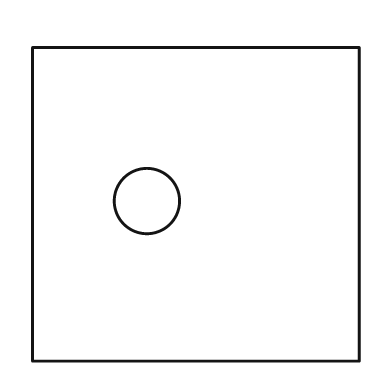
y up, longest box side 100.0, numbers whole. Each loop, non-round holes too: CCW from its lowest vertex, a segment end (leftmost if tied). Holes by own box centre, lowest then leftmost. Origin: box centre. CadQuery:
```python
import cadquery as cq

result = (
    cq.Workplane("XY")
    .moveTo(-50.0, -48.0)
    .lineTo(50.0, -48.0)
    .lineTo(50.0, 48.0)
    .lineTo(-50.0, 48.0)
    .close()
    .moveTo(-15.0, 1.0)
    .circle(10.0)
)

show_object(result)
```